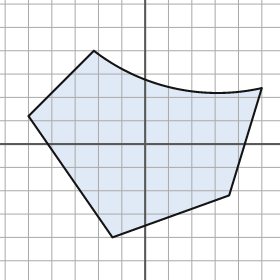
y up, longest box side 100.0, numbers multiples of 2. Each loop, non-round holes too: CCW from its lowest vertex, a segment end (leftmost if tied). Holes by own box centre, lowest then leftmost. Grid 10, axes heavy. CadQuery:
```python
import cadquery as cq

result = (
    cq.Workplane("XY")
    .moveTo(-14.0, -40.0)
    .lineTo(36.0, -22.0)
    .lineTo(50.0, 24.0)
    .threePointArc((12.0, 24.0), (-22.0, 40.0))
    .lineTo(-50.0, 12.0)
    .close()
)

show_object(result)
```